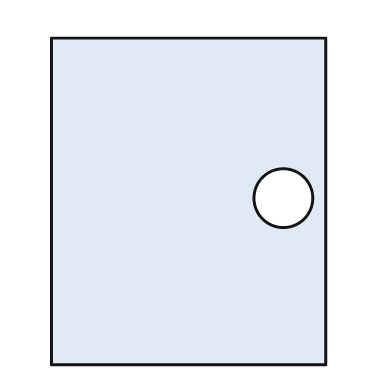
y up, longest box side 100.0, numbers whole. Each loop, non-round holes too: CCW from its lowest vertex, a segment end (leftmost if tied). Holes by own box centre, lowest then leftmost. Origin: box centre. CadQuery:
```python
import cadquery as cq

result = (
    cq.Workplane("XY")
    .moveTo(-42.0, -50.0)
    .lineTo(42.0, -50.0)
    .lineTo(42.0, 50.0)
    .lineTo(-42.0, 50.0)
    .close()
    .moveTo(29.0, 1.0)
    .circle(9.0)
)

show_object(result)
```